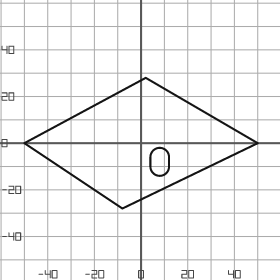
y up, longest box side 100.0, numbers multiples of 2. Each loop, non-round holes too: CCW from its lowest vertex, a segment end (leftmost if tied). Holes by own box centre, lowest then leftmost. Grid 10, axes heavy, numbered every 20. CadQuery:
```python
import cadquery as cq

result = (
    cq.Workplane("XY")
    .moveTo(-8.0, -28.0)
    .lineTo(50.0, 0.0)
    .lineTo(2.0, 28.0)
    .lineTo(-50.0, 0.0)
    .close()
    .moveTo(4.0, -10.0)
    .threePointArc((8.0, -14.0), (12.0, -10.0))
    .lineTo(12.0, -6.0)
    .threePointArc((8.0, -2.0), (4.0, -6.0))
    .close()
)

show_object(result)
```